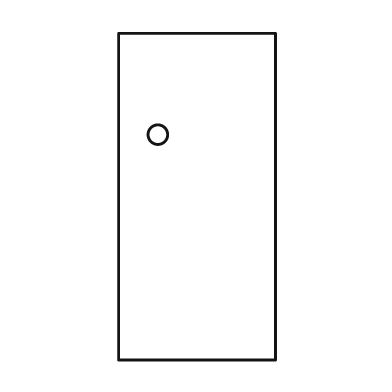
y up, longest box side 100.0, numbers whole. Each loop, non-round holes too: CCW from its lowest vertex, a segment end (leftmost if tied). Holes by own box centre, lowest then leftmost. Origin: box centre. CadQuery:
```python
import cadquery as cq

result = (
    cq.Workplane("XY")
    .moveTo(-24.0, -50.0)
    .lineTo(24.0, -50.0)
    .lineTo(24.0, 50.0)
    .lineTo(-24.0, 50.0)
    .close()
    .moveTo(-12.0, 19.0)
    .circle(3.0)
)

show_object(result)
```